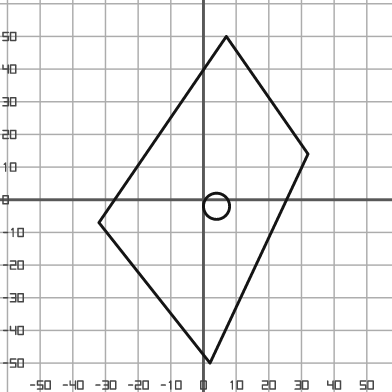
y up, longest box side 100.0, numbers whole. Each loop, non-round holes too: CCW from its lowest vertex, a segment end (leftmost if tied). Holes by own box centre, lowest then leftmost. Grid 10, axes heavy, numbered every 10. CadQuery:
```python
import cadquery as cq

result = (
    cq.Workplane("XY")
    .moveTo(2.0, -50.0)
    .lineTo(32.0, 14.0)
    .lineTo(7.0, 50.0)
    .lineTo(-32.0, -7.0)
    .close()
    .moveTo(4.0, -2.0)
    .circle(4.0)
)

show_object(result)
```